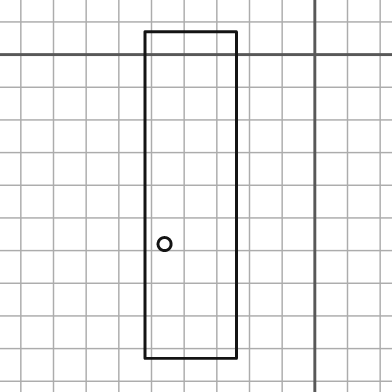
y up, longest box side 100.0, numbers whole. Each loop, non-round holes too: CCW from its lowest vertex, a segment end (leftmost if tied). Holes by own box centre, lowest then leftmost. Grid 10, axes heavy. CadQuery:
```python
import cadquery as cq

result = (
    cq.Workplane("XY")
    .moveTo(-52.0, -93.0)
    .lineTo(-24.0, -93.0)
    .lineTo(-24.0, 7.0)
    .lineTo(-52.0, 7.0)
    .close()
    .moveTo(-46.0, -58.0)
    .circle(2.0)
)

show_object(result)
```